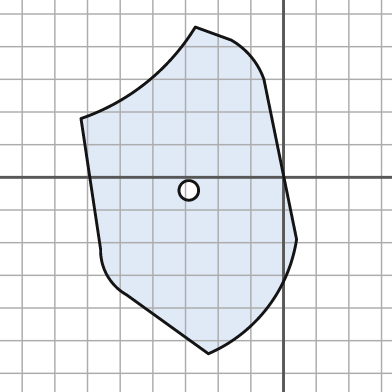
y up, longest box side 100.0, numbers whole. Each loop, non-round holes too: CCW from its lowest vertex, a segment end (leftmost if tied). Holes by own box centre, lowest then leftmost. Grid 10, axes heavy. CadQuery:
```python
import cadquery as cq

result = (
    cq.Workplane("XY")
    .moveTo(-23.0, -54.0)
    .threePointArc((-5.0, -40.0), (4.0, -19.0))
    .lineTo(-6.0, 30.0)
    .threePointArc((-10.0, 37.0), (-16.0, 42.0))
    .lineTo(-27.0, 46.0)
    .threePointArc((-42.0, 29.0), (-62.0, 18.0))
    .lineTo(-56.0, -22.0)
    .threePointArc((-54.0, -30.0), (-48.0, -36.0))
    .close()
    .moveTo(-29.0, -4.0)
    .circle(3.0)
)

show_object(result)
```